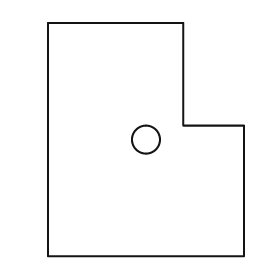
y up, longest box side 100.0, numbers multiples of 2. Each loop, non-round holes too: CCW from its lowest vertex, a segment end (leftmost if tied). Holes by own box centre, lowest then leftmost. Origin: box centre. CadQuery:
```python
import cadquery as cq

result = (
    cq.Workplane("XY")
    .moveTo(-42.0, -50.0)
    .lineTo(42.0, -50.0)
    .lineTo(42.0, 6.0)
    .lineTo(16.0, 6.0)
    .lineTo(16.0, 50.0)
    .lineTo(-42.0, 50.0)
    .close()
    .moveTo(0.0, 0.0)
    .circle(6.0)
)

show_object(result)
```